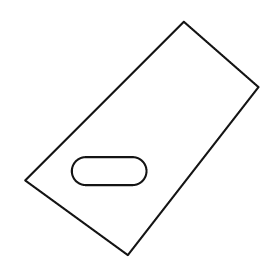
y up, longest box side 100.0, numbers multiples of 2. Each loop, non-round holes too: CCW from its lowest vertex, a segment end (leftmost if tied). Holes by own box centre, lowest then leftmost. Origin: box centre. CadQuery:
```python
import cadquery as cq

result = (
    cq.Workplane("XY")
    .moveTo(-6.0, -50.0)
    .lineTo(50.0, 22.0)
    .lineTo(18.0, 50.0)
    .lineTo(-50.0, -18.0)
    .close()
    .moveTo(-24.0, -20.0)
    .lineTo(-4.0, -20.0)
    .threePointArc((2.0, -14.0), (-4.0, -8.0))
    .lineTo(-24.0, -8.0)
    .threePointArc((-30.0, -14.0), (-24.0, -20.0))
    .close()
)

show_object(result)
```